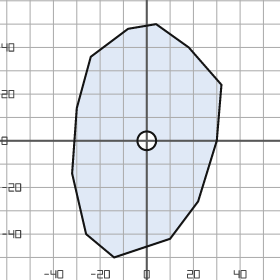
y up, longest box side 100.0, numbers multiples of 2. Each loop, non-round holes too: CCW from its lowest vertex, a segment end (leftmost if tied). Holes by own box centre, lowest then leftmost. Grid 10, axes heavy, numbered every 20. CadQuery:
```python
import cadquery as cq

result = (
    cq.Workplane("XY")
    .moveTo(-14.0, -50.0)
    .lineTo(10.0, -42.0)
    .lineTo(22.0, -26.0)
    .lineTo(30.0, 0.0)
    .lineTo(32.0, 24.0)
    .lineTo(18.0, 40.0)
    .lineTo(4.0, 50.0)
    .lineTo(-8.0, 48.0)
    .lineTo(-24.0, 36.0)
    .lineTo(-30.0, 14.0)
    .lineTo(-32.0, -14.0)
    .lineTo(-26.0, -40.0)
    .close()
    .moveTo(0.0, 0.0)
    .circle(4.0)
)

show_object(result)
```